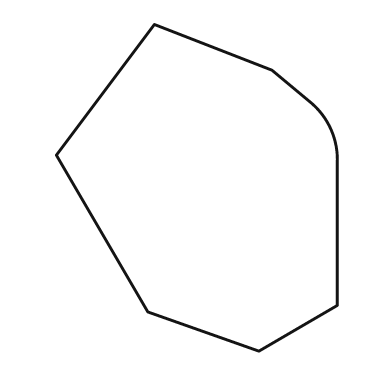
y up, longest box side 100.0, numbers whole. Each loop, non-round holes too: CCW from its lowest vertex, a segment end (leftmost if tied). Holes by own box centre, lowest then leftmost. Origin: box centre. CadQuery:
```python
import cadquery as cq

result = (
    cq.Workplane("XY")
    .moveTo(19.0, -50.0)
    .lineTo(43.0, -36.0)
    .lineTo(43.0, 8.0)
    .threePointArc((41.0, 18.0), (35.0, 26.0))
    .lineTo(23.0, 36.0)
    .lineTo(-13.0, 50.0)
    .lineTo(-43.0, 10.0)
    .lineTo(-15.0, -38.0)
    .close()
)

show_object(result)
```